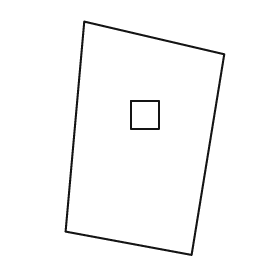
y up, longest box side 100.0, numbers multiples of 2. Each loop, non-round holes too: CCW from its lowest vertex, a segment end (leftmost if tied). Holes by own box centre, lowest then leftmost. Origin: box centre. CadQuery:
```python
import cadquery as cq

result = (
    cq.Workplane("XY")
    .moveTo(20.0, -50.0)
    .lineTo(34.0, 36.0)
    .lineTo(-26.0, 50.0)
    .lineTo(-34.0, -40.0)
    .close()
    .moveTo(-6.0, 4.0)
    .lineTo(6.0, 4.0)
    .lineTo(6.0, 16.0)
    .lineTo(-6.0, 16.0)
    .close()
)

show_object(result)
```